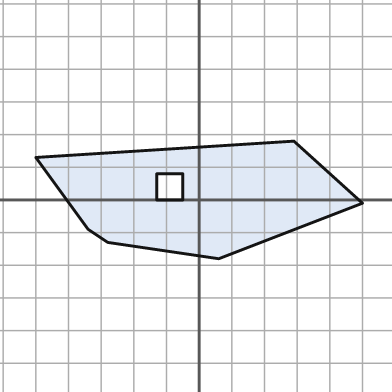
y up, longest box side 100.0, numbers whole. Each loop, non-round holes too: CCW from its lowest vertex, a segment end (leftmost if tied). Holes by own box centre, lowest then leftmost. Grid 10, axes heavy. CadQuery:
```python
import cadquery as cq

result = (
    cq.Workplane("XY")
    .moveTo(6.0, -18.0)
    .lineTo(50.0, -1.0)
    .lineTo(29.0, 18.0)
    .lineTo(-50.0, 13.0)
    .lineTo(-34.0, -9.0)
    .lineTo(-28.0, -13.0)
    .close()
    .moveTo(-13.0, 0.0)
    .lineTo(-5.0, 0.0)
    .lineTo(-5.0, 8.0)
    .lineTo(-13.0, 8.0)
    .close()
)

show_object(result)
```